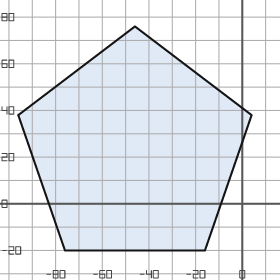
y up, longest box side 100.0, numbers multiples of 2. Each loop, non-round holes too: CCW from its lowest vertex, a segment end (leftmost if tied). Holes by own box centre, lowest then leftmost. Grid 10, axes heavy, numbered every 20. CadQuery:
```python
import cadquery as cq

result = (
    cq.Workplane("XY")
    .moveTo(-76.0, -20.0)
    .lineTo(-16.0, -20.0)
    .lineTo(4.0, 38.0)
    .lineTo(-46.0, 76.0)
    .lineTo(-96.0, 38.0)
    .close()
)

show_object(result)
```